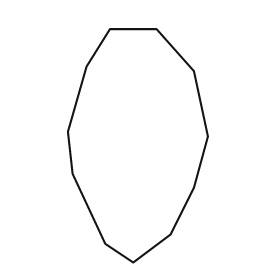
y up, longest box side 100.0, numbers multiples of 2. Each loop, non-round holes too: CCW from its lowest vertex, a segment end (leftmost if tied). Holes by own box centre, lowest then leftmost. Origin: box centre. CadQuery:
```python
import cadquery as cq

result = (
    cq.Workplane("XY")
    .moveTo(-2.0, -50.0)
    .lineTo(14.0, -38.0)
    .lineTo(24.0, -18.0)
    .lineTo(30.0, 4.0)
    .lineTo(24.0, 32.0)
    .lineTo(8.0, 50.0)
    .lineTo(-12.0, 50.0)
    .lineTo(-22.0, 34.0)
    .lineTo(-30.0, 6.0)
    .lineTo(-28.0, -12.0)
    .lineTo(-14.0, -42.0)
    .close()
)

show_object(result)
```